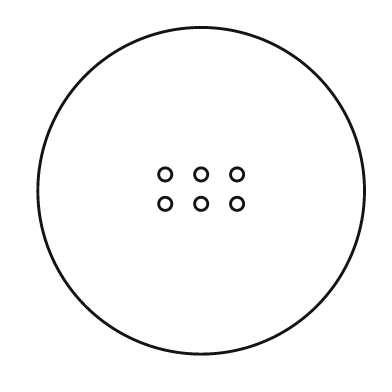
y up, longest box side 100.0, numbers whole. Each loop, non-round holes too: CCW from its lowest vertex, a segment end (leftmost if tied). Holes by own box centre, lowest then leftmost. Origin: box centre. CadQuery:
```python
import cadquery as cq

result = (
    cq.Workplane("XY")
    .moveTo(0.0, 0.0)
    .circle(50.0)
    .moveTo(-11.0, -4.0)
    .circle(2.0)
    .moveTo(0.0, -4.0)
    .circle(2.0)
    .moveTo(11.0, -4.0)
    .circle(2.0)
    .moveTo(-11.0, 5.0)
    .circle(2.0)
    .moveTo(0.0, 5.0)
    .circle(2.0)
    .moveTo(11.0, 5.0)
    .circle(2.0)
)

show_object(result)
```